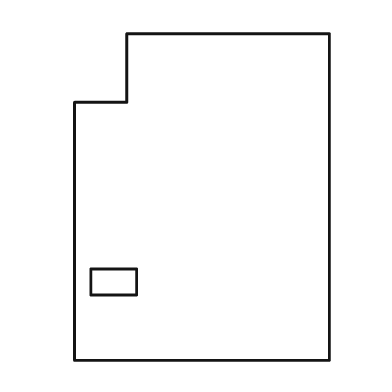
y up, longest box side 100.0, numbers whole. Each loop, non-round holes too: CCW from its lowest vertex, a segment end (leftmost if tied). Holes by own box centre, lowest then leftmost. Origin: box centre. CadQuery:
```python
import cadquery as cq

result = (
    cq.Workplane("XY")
    .moveTo(-39.0, -50.0)
    .lineTo(39.0, -50.0)
    .lineTo(39.0, 50.0)
    .lineTo(-23.0, 50.0)
    .lineTo(-23.0, 29.0)
    .lineTo(-39.0, 29.0)
    .close()
    .moveTo(-34.0, -30.0)
    .lineTo(-20.0, -30.0)
    .lineTo(-20.0, -22.0)
    .lineTo(-34.0, -22.0)
    .close()
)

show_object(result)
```